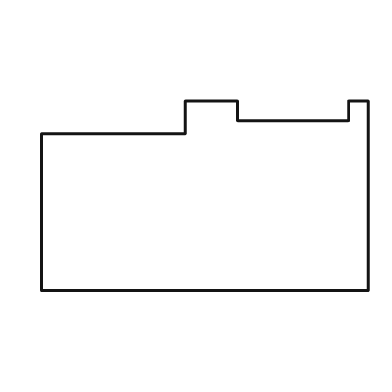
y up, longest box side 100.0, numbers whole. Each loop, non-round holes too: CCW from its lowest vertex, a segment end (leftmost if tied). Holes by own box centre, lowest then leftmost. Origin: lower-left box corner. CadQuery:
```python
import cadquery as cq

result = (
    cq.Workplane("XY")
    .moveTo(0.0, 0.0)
    .lineTo(100.0, 0.0)
    .lineTo(100.0, 58.0)
    .lineTo(94.0, 58.0)
    .lineTo(94.0, 52.0)
    .lineTo(60.0, 52.0)
    .lineTo(60.0, 58.0)
    .lineTo(44.0, 58.0)
    .lineTo(44.0, 48.0)
    .lineTo(0.0, 48.0)
    .close()
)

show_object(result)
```